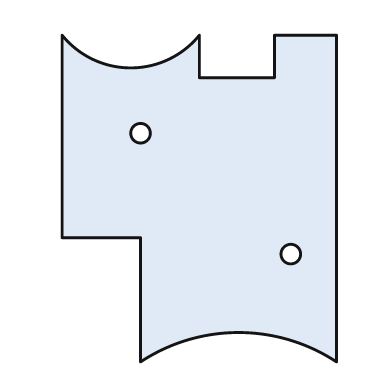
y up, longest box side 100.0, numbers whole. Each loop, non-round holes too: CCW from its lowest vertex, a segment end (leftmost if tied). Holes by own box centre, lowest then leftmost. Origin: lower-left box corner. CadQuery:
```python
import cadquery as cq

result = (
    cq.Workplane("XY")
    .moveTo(24.0, 0.0)
    .threePointArc((54.0, 9.0), (84.0, 0.0))
    .lineTo(84.0, 100.0)
    .lineTo(65.0, 100.0)
    .lineTo(65.0, 87.0)
    .lineTo(42.0, 87.0)
    .lineTo(42.0, 100.0)
    .threePointArc((21.0, 90.0), (0.0, 100.0))
    .lineTo(0.0, 38.0)
    .lineTo(24.0, 38.0)
    .close()
    .moveTo(70.0, 33.0)
    .circle(3.0)
    .moveTo(24.0, 70.0)
    .circle(3.0)
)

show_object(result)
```